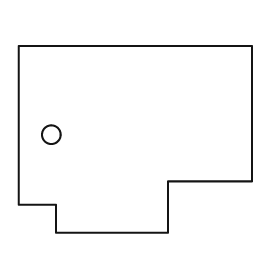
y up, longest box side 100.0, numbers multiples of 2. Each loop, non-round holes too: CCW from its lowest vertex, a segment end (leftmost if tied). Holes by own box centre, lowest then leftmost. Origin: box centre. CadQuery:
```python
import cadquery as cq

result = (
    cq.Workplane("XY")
    .moveTo(-34.0, -40.0)
    .lineTo(14.0, -40.0)
    .lineTo(14.0, -18.0)
    .lineTo(50.0, -18.0)
    .lineTo(50.0, 40.0)
    .lineTo(-50.0, 40.0)
    .lineTo(-50.0, -28.0)
    .lineTo(-34.0, -28.0)
    .close()
    .moveTo(-36.0, 2.0)
    .circle(4.0)
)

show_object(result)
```